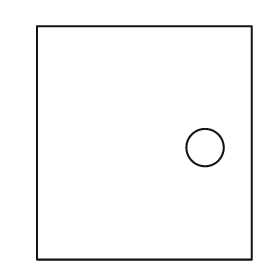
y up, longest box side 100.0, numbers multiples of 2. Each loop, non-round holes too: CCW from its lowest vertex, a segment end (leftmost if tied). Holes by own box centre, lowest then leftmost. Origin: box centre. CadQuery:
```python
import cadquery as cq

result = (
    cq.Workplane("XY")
    .moveTo(-46.0, -50.0)
    .lineTo(46.0, -50.0)
    .lineTo(46.0, 50.0)
    .lineTo(-46.0, 50.0)
    .close()
    .moveTo(26.0, -2.0)
    .circle(8.0)
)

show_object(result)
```